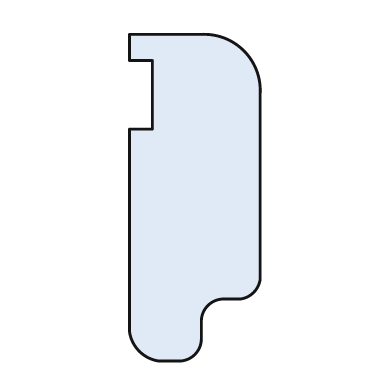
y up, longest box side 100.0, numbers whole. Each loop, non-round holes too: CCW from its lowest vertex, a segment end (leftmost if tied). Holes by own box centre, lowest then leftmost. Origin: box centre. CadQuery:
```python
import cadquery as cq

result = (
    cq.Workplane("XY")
    .moveTo(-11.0, -50.0)
    .lineTo(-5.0, -50.0)
    .threePointArc((0.0, -48.0), (2.0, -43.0))
    .lineTo(2.0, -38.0)
    .threePointArc((4.0, -33.0), (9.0, -31.0))
    .lineTo(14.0, -31.0)
    .threePointArc((18.0, -29.0), (20.0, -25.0))
    .lineTo(20.0, 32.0)
    .threePointArc((15.0, 45.0), (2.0, 50.0))
    .lineTo(-20.0, 50.0)
    .lineTo(-20.0, 42.0)
    .lineTo(-13.0, 42.0)
    .lineTo(-13.0, 21.0)
    .lineTo(-20.0, 21.0)
    .lineTo(-20.0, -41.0)
    .threePointArc((-17.0, -47.0), (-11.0, -50.0))
    .close()
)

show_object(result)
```